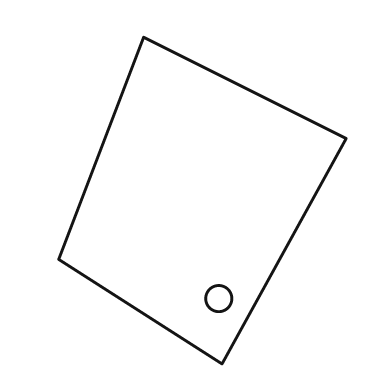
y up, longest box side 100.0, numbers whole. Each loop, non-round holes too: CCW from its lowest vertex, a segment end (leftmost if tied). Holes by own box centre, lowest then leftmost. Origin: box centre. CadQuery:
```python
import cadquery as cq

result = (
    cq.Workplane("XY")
    .moveTo(6.0, -50.0)
    .lineTo(44.0, 19.0)
    .lineTo(-18.0, 50.0)
    .lineTo(-44.0, -18.0)
    .close()
    .moveTo(5.0, -30.0)
    .circle(4.0)
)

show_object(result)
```